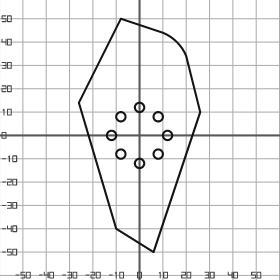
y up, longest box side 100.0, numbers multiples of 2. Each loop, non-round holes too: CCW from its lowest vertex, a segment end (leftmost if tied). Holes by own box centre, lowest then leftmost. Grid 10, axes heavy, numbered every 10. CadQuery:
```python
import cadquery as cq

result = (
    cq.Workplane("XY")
    .moveTo(6.0, -50.0)
    .lineTo(26.0, 10.0)
    .lineTo(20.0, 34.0)
    .threePointArc((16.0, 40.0), (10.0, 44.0))
    .lineTo(-8.0, 50.0)
    .lineTo(-26.0, 14.0)
    .lineTo(-10.0, -40.0)
    .close()
    .moveTo(0.0, -12.0)
    .circle(2.0)
    .moveTo(-8.0, -8.0)
    .circle(2.0)
    .moveTo(8.0, -8.0)
    .circle(2.0)
    .moveTo(-12.0, 0.0)
    .circle(2.0)
    .moveTo(12.0, 0.0)
    .circle(2.0)
    .moveTo(-8.0, 8.0)
    .circle(2.0)
    .moveTo(8.0, 8.0)
    .circle(2.0)
    .moveTo(0.0, 12.0)
    .circle(2.0)
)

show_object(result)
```